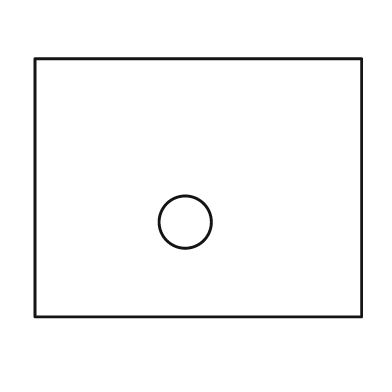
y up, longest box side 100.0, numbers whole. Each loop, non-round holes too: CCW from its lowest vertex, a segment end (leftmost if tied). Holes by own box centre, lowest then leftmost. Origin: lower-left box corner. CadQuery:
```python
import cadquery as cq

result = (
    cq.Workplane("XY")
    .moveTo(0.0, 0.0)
    .lineTo(100.0, 0.0)
    .lineTo(100.0, 79.0)
    .lineTo(0.0, 79.0)
    .close()
    .moveTo(46.0, 29.0)
    .circle(8.0)
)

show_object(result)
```